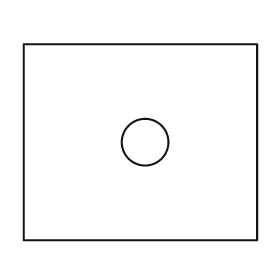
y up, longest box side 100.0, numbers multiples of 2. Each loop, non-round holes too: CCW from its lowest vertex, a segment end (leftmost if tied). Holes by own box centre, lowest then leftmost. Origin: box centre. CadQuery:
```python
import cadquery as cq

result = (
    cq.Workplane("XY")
    .moveTo(-50.0, -42.0)
    .lineTo(50.0, -42.0)
    .lineTo(50.0, 42.0)
    .lineTo(-50.0, 42.0)
    .close()
    .moveTo(2.0, 0.0)
    .circle(10.0)
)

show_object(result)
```